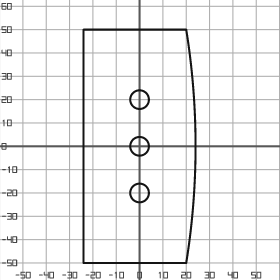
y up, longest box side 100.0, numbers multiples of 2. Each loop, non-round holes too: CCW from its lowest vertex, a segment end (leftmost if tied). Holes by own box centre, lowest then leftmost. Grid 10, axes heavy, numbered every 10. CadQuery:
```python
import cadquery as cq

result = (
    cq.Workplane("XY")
    .moveTo(-24.0, -50.0)
    .lineTo(20.0, -50.0)
    .threePointArc((24.0, 0.0), (20.0, 50.0))
    .lineTo(-24.0, 50.0)
    .close()
    .moveTo(0.0, -20.0)
    .circle(4.0)
    .moveTo(0.0, 0.0)
    .circle(4.0)
    .moveTo(0.0, 20.0)
    .circle(4.0)
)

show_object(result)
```